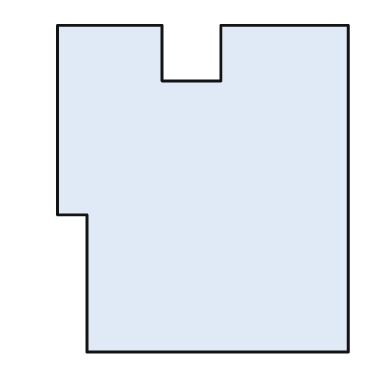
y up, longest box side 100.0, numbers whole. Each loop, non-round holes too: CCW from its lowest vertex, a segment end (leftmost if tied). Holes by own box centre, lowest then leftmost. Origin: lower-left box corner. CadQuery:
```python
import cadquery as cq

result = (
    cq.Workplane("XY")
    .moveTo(9.0, 0.0)
    .lineTo(89.0, 0.0)
    .lineTo(89.0, 100.0)
    .lineTo(50.0, 100.0)
    .lineTo(50.0, 83.0)
    .lineTo(32.0, 83.0)
    .lineTo(32.0, 100.0)
    .lineTo(0.0, 100.0)
    .lineTo(0.0, 42.0)
    .lineTo(9.0, 42.0)
    .close()
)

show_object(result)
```